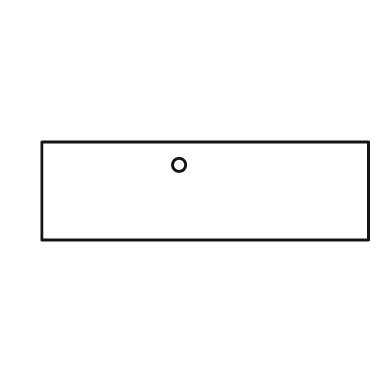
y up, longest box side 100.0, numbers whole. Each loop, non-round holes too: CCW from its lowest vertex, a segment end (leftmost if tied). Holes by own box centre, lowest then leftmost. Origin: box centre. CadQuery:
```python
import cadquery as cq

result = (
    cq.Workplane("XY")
    .moveTo(-50.0, -15.0)
    .lineTo(50.0, -15.0)
    .lineTo(50.0, 15.0)
    .lineTo(-50.0, 15.0)
    .close()
    .moveTo(-8.0, 8.0)
    .circle(2.0)
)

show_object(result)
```